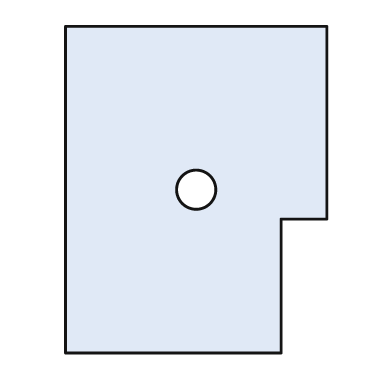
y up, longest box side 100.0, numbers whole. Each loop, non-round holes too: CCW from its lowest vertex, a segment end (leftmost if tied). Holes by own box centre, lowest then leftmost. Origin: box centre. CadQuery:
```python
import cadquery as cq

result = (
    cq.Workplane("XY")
    .moveTo(-40.0, -50.0)
    .lineTo(26.0, -50.0)
    .lineTo(26.0, -9.0)
    .lineTo(40.0, -9.0)
    .lineTo(40.0, 50.0)
    .lineTo(-40.0, 50.0)
    .close()
    .moveTo(0.0, 0.0)
    .circle(6.0)
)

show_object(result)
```